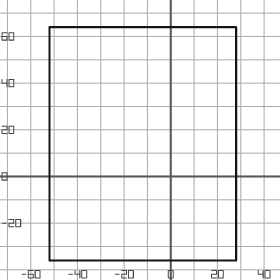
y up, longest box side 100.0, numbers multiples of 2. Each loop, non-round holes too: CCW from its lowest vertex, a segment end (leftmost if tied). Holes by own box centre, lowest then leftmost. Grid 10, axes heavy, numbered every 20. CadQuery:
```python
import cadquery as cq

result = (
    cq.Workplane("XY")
    .moveTo(-52.0, -36.0)
    .lineTo(28.0, -36.0)
    .lineTo(28.0, 64.0)
    .lineTo(-52.0, 64.0)
    .close()
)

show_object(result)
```